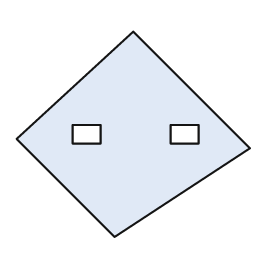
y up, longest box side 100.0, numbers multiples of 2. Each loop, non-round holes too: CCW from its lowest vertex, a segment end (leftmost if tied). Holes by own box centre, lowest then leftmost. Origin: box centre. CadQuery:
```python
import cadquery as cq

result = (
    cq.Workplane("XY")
    .moveTo(-8.0, -44.0)
    .lineTo(50.0, -6.0)
    .lineTo(0.0, 44.0)
    .lineTo(-50.0, -2.0)
    .close()
    .moveTo(-26.0, -4.0)
    .lineTo(-14.0, -4.0)
    .lineTo(-14.0, 4.0)
    .lineTo(-26.0, 4.0)
    .close()
    .moveTo(16.0, -4.0)
    .lineTo(28.0, -4.0)
    .lineTo(28.0, 4.0)
    .lineTo(16.0, 4.0)
    .close()
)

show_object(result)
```